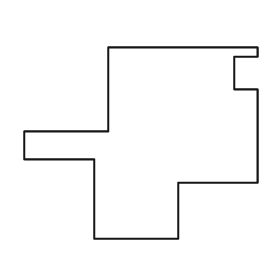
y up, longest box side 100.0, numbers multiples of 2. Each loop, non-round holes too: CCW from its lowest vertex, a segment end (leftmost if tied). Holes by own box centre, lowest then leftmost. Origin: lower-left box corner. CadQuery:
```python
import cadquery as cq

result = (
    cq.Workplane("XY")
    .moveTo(30.0, 0.0)
    .lineTo(66.0, 0.0)
    .lineTo(66.0, 24.0)
    .lineTo(100.0, 24.0)
    .lineTo(100.0, 64.0)
    .lineTo(90.0, 64.0)
    .lineTo(90.0, 78.0)
    .lineTo(100.0, 78.0)
    .lineTo(100.0, 82.0)
    .lineTo(36.0, 82.0)
    .lineTo(36.0, 46.0)
    .lineTo(0.0, 46.0)
    .lineTo(0.0, 34.0)
    .lineTo(30.0, 34.0)
    .close()
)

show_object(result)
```